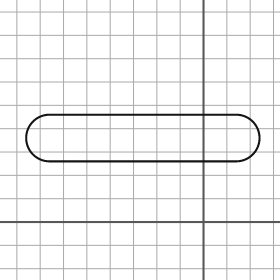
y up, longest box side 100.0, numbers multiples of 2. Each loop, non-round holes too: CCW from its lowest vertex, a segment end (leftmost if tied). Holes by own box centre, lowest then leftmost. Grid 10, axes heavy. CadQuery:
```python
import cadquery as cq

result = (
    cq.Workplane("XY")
    .moveTo(-66.0, 26.0)
    .lineTo(14.0, 26.0)
    .threePointArc((24.0, 36.0), (14.0, 46.0))
    .lineTo(-66.0, 46.0)
    .threePointArc((-76.0, 36.0), (-66.0, 26.0))
    .close()
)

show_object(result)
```